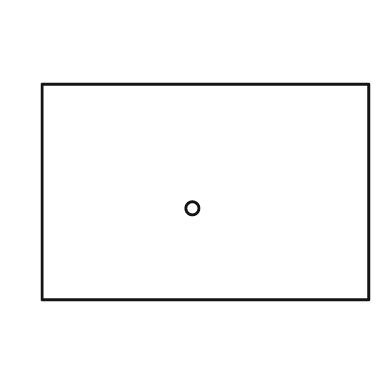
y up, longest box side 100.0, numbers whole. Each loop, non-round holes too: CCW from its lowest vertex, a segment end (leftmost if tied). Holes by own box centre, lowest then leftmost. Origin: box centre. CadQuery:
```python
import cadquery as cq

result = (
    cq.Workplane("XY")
    .moveTo(-50.0, -33.0)
    .lineTo(50.0, -33.0)
    .lineTo(50.0, 33.0)
    .lineTo(-50.0, 33.0)
    .close()
    .moveTo(-4.0, -5.0)
    .circle(2.0)
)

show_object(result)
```